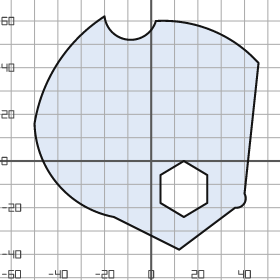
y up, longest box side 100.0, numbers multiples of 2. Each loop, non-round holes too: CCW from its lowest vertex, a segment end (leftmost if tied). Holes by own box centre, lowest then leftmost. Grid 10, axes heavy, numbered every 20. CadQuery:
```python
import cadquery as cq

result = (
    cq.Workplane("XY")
    .moveTo(12.0, -38.0)
    .lineTo(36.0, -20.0)
    .threePointArc((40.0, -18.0), (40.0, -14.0))
    .lineTo(46.0, 42.0)
    .threePointArc((26.0, 56.0), (2.0, 60.0))
    .threePointArc((-10.0, 52.0), (-20.0, 62.0))
    .threePointArc((-40.0, 42.0), (-50.0, 16.0))
    .threePointArc((-40.0, -10.0), (-16.0, -24.0))
    .close()
    .moveTo(14.0, -24.0)
    .lineTo(24.0, -18.0)
    .lineTo(24.0, -6.0)
    .lineTo(14.0, 0.0)
    .lineTo(4.0, -6.0)
    .lineTo(4.0, -18.0)
    .close()
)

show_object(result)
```